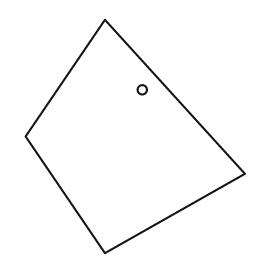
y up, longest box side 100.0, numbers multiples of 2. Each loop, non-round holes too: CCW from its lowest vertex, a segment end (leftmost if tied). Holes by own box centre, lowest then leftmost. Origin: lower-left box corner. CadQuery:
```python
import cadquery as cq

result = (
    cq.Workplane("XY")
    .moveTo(34.0, 0.0)
    .lineTo(94.0, 34.0)
    .lineTo(34.0, 100.0)
    .lineTo(0.0, 50.0)
    .close()
    .moveTo(50.0, 70.0)
    .circle(2.0)
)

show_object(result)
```